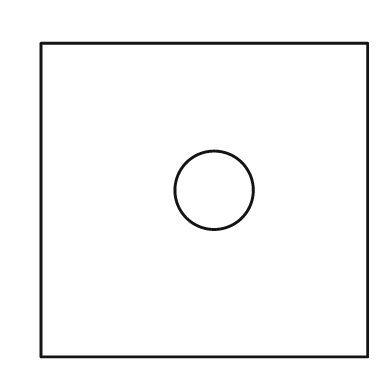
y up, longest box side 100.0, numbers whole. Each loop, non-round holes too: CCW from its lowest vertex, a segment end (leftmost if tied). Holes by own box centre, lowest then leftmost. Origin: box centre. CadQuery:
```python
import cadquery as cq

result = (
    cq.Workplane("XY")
    .moveTo(-50.0, -48.0)
    .lineTo(50.0, -48.0)
    .lineTo(50.0, 48.0)
    .lineTo(-50.0, 48.0)
    .close()
    .moveTo(3.0, 3.0)
    .circle(12.0)
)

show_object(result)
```